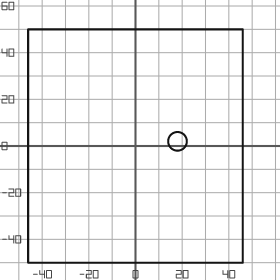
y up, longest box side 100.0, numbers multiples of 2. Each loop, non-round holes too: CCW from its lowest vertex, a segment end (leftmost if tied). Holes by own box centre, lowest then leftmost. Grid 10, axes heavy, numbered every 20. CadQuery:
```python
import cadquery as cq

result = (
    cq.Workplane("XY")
    .moveTo(-46.0, -50.0)
    .lineTo(46.0, -50.0)
    .lineTo(46.0, 50.0)
    .lineTo(-46.0, 50.0)
    .close()
    .moveTo(18.0, 2.0)
    .circle(4.0)
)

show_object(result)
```